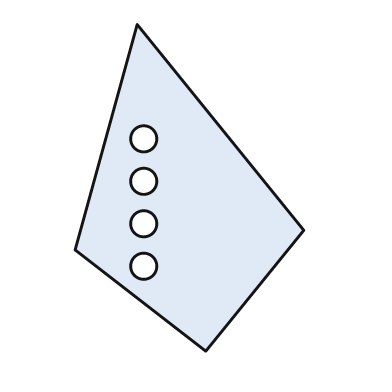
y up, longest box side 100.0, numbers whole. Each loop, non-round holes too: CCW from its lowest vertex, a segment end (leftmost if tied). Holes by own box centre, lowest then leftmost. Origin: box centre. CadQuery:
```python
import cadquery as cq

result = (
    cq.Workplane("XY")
    .moveTo(5.0, -50.0)
    .lineTo(35.0, -13.0)
    .lineTo(-16.0, 50.0)
    .lineTo(-35.0, -19.0)
    .close()
    .moveTo(-14.0, -24.0)
    .circle(4.0)
    .moveTo(-14.0, -11.0)
    .circle(4.0)
    .moveTo(-14.0, 2.0)
    .circle(4.0)
    .moveTo(-14.0, 15.0)
    .circle(4.0)
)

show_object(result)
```